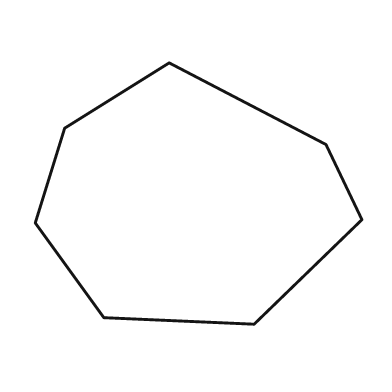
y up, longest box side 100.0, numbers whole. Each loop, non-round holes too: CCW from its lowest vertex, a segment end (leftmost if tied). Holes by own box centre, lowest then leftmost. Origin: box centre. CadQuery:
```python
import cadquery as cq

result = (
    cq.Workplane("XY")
    .moveTo(17.0, -40.0)
    .lineTo(50.0, -8.0)
    .lineTo(39.0, 15.0)
    .lineTo(-9.0, 40.0)
    .lineTo(-41.0, 20.0)
    .lineTo(-50.0, -9.0)
    .lineTo(-29.0, -38.0)
    .close()
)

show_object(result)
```